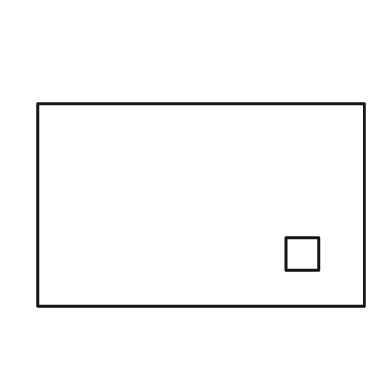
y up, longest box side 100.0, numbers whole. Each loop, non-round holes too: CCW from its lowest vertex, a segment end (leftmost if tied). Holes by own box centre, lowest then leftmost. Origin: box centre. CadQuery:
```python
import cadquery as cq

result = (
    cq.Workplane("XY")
    .moveTo(-50.0, -31.0)
    .lineTo(50.0, -31.0)
    .lineTo(50.0, 31.0)
    .lineTo(-50.0, 31.0)
    .close()
    .moveTo(26.0, -20.0)
    .lineTo(36.0, -20.0)
    .lineTo(36.0, -10.0)
    .lineTo(26.0, -10.0)
    .close()
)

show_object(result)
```